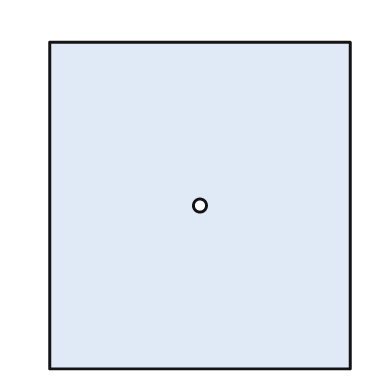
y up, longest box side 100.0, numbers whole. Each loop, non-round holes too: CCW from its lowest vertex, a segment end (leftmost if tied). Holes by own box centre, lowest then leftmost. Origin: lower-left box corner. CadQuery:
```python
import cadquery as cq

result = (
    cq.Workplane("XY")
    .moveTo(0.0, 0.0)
    .lineTo(92.0, 0.0)
    .lineTo(92.0, 100.0)
    .lineTo(0.0, 100.0)
    .close()
    .moveTo(46.0, 50.0)
    .circle(2.0)
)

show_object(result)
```